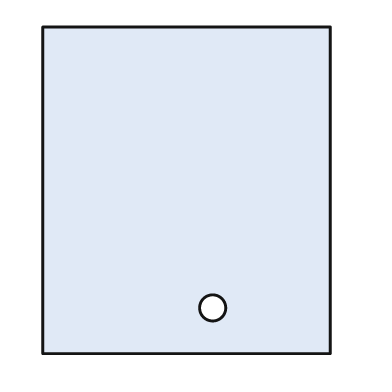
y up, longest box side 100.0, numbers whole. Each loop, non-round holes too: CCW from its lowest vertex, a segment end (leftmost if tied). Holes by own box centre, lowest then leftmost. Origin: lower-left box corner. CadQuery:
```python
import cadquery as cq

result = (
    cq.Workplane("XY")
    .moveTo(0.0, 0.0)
    .lineTo(88.0, 0.0)
    .lineTo(88.0, 100.0)
    .lineTo(0.0, 100.0)
    .close()
    .moveTo(52.0, 14.0)
    .circle(4.0)
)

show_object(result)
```